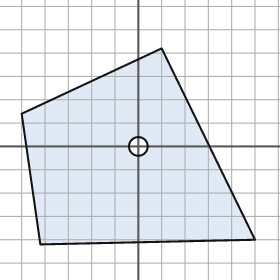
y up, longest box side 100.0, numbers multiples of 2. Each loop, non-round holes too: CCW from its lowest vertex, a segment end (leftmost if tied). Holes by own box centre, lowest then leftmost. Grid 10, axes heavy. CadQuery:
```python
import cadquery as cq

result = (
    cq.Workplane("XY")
    .moveTo(-42.0, -42.0)
    .lineTo(50.0, -40.0)
    .lineTo(10.0, 42.0)
    .lineTo(-50.0, 14.0)
    .close()
    .moveTo(0.0, 0.0)
    .circle(4.0)
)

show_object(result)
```